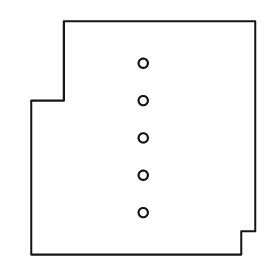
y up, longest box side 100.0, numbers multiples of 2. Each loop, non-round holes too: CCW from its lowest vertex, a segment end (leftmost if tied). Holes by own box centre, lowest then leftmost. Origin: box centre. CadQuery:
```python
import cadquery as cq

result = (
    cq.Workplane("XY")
    .moveTo(-48.0, -50.0)
    .lineTo(42.0, -50.0)
    .lineTo(42.0, -40.0)
    .lineTo(48.0, -40.0)
    .lineTo(48.0, 50.0)
    .lineTo(-34.0, 50.0)
    .lineTo(-34.0, 16.0)
    .lineTo(-48.0, 16.0)
    .close()
    .moveTo(0.0, -32.0)
    .circle(2.0)
    .moveTo(0.0, -16.0)
    .circle(2.0)
    .moveTo(0.0, 0.0)
    .circle(2.0)
    .moveTo(0.0, 16.0)
    .circle(2.0)
    .moveTo(0.0, 32.0)
    .circle(2.0)
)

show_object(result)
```